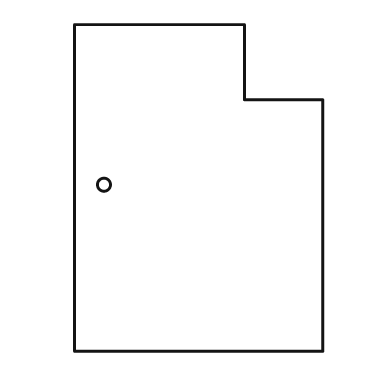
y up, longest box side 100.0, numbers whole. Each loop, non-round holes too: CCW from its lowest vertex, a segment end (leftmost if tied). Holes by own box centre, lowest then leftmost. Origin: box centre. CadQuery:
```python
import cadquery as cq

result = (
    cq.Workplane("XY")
    .moveTo(-38.0, -50.0)
    .lineTo(38.0, -50.0)
    .lineTo(38.0, 27.0)
    .lineTo(14.0, 27.0)
    .lineTo(14.0, 50.0)
    .lineTo(-38.0, 50.0)
    .close()
    .moveTo(-29.0, 1.0)
    .circle(2.0)
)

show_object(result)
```